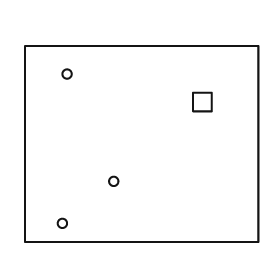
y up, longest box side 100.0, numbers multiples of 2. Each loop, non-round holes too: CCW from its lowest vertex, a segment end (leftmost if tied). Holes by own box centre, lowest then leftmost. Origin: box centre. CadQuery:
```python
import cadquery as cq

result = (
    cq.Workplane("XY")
    .moveTo(-50.0, -42.0)
    .lineTo(50.0, -42.0)
    .lineTo(50.0, 42.0)
    .lineTo(-50.0, 42.0)
    .close()
    .moveTo(-34.0, -34.0)
    .circle(2.0)
    .moveTo(-12.0, -16.0)
    .circle(2.0)
    .moveTo(22.0, 14.0)
    .lineTo(30.0, 14.0)
    .lineTo(30.0, 22.0)
    .lineTo(22.0, 22.0)
    .close()
    .moveTo(-32.0, 30.0)
    .circle(2.0)
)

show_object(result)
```